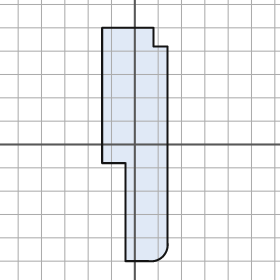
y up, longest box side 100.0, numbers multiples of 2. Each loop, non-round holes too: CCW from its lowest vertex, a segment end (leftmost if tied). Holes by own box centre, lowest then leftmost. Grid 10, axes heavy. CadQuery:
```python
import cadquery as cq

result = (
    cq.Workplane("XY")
    .moveTo(-4.0, -50.0)
    .lineTo(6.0, -50.0)
    .threePointArc((12.0, -48.0), (14.0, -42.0))
    .lineTo(14.0, 42.0)
    .lineTo(8.0, 42.0)
    .lineTo(8.0, 50.0)
    .lineTo(-14.0, 50.0)
    .lineTo(-14.0, -8.0)
    .lineTo(-4.0, -8.0)
    .close()
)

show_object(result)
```